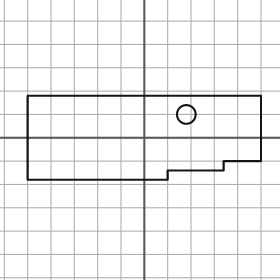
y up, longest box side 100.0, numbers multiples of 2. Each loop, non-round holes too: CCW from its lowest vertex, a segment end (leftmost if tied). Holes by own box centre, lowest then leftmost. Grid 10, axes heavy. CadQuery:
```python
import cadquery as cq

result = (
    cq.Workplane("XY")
    .moveTo(-50.0, -18.0)
    .lineTo(10.0, -18.0)
    .lineTo(10.0, -14.0)
    .lineTo(34.0, -14.0)
    .lineTo(34.0, -10.0)
    .lineTo(50.0, -10.0)
    .lineTo(50.0, 18.0)
    .lineTo(-50.0, 18.0)
    .close()
    .moveTo(18.0, 10.0)
    .circle(4.0)
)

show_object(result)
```